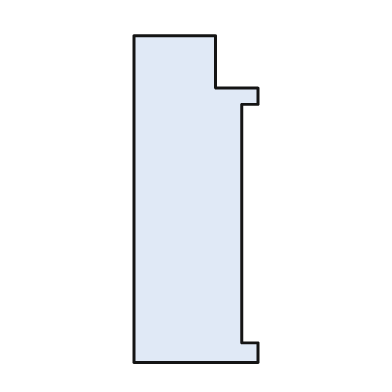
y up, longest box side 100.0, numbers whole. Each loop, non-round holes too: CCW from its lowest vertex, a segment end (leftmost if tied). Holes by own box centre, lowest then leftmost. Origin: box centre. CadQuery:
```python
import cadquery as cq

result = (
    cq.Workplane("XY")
    .moveTo(-19.0, -50.0)
    .lineTo(19.0, -50.0)
    .lineTo(19.0, -44.0)
    .lineTo(14.0, -44.0)
    .lineTo(14.0, 29.0)
    .lineTo(19.0, 29.0)
    .lineTo(19.0, 34.0)
    .lineTo(6.0, 34.0)
    .lineTo(6.0, 50.0)
    .lineTo(-19.0, 50.0)
    .close()
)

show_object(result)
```